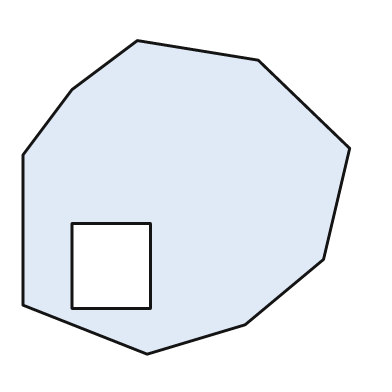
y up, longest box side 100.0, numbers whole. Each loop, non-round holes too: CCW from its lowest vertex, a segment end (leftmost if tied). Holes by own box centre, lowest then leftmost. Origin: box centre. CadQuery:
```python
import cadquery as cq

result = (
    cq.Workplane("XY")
    .moveTo(-12.0, -48.0)
    .lineTo(18.0, -39.0)
    .lineTo(42.0, -19.0)
    .lineTo(50.0, 15.0)
    .lineTo(22.0, 42.0)
    .lineTo(-15.0, 48.0)
    .lineTo(-35.0, 33.0)
    .lineTo(-50.0, 13.0)
    .lineTo(-50.0, -33.0)
    .close()
    .moveTo(-35.0, -34.0)
    .lineTo(-11.0, -34.0)
    .lineTo(-11.0, -8.0)
    .lineTo(-35.0, -8.0)
    .close()
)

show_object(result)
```